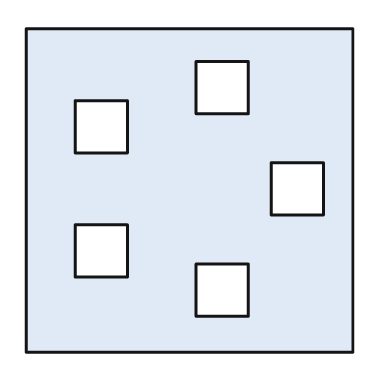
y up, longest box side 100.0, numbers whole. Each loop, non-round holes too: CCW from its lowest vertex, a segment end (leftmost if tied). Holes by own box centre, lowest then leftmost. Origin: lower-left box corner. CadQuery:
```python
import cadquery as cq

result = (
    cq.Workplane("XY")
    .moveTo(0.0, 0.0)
    .lineTo(100.0, 0.0)
    .lineTo(100.0, 99.0)
    .lineTo(0.0, 99.0)
    .close()
    .moveTo(52.0, 11.0)
    .lineTo(68.0, 11.0)
    .lineTo(68.0, 27.0)
    .lineTo(52.0, 27.0)
    .close()
    .moveTo(15.0, 23.0)
    .lineTo(31.0, 23.0)
    .lineTo(31.0, 39.0)
    .lineTo(15.0, 39.0)
    .close()
    .moveTo(75.0, 42.0)
    .lineTo(91.0, 42.0)
    .lineTo(91.0, 58.0)
    .lineTo(75.0, 58.0)
    .close()
    .moveTo(15.0, 61.0)
    .lineTo(31.0, 61.0)
    .lineTo(31.0, 77.0)
    .lineTo(15.0, 77.0)
    .close()
    .moveTo(52.0, 73.0)
    .lineTo(68.0, 73.0)
    .lineTo(68.0, 89.0)
    .lineTo(52.0, 89.0)
    .close()
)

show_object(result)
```